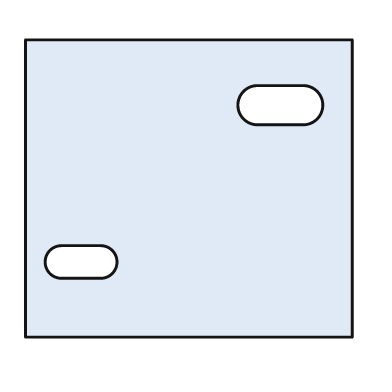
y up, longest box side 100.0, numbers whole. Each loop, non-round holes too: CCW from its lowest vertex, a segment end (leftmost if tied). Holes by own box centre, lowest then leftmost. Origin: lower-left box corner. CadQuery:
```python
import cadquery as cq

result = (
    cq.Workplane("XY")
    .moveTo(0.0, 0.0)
    .lineTo(100.0, 0.0)
    .lineTo(100.0, 91.0)
    .lineTo(0.0, 91.0)
    .close()
    .moveTo(11.0, 18.0)
    .lineTo(23.0, 18.0)
    .threePointArc((28.0, 23.0), (23.0, 28.0))
    .lineTo(11.0, 28.0)
    .threePointArc((6.0, 23.0), (11.0, 18.0))
    .close()
    .moveTo(71.0, 65.0)
    .lineTo(85.0, 65.0)
    .threePointArc((91.0, 71.0), (85.0, 77.0))
    .lineTo(71.0, 77.0)
    .threePointArc((65.0, 71.0), (71.0, 65.0))
    .close()
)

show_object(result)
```